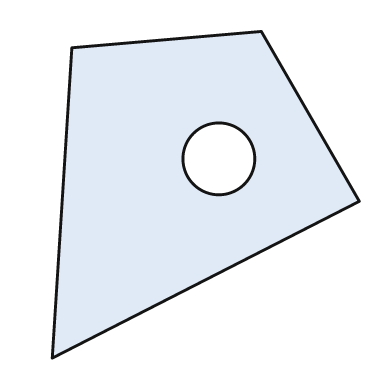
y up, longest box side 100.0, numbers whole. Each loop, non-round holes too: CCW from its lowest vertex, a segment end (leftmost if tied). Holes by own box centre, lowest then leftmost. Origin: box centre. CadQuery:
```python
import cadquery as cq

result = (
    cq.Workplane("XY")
    .moveTo(-47.0, -50.0)
    .lineTo(47.0, -2.0)
    .lineTo(17.0, 50.0)
    .lineTo(-41.0, 45.0)
    .close()
    .moveTo(4.0, 11.0)
    .circle(11.0)
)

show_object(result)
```